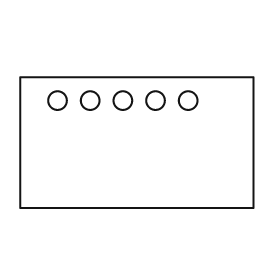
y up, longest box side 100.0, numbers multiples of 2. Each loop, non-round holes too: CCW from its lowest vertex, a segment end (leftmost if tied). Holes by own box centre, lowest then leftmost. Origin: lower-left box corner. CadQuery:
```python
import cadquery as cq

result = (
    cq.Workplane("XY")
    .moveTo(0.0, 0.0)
    .lineTo(100.0, 0.0)
    .lineTo(100.0, 56.0)
    .lineTo(0.0, 56.0)
    .close()
    .moveTo(16.0, 46.0)
    .circle(4.0)
    .moveTo(30.0, 46.0)
    .circle(4.0)
    .moveTo(44.0, 46.0)
    .circle(4.0)
    .moveTo(58.0, 46.0)
    .circle(4.0)
    .moveTo(72.0, 46.0)
    .circle(4.0)
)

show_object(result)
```